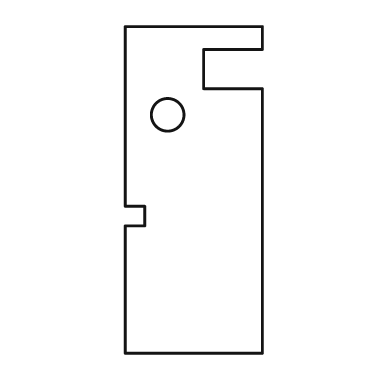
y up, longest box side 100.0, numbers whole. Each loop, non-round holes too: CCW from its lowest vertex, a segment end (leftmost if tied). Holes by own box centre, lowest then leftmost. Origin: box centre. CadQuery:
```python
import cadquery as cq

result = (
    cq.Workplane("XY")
    .moveTo(-21.0, -50.0)
    .lineTo(21.0, -50.0)
    .lineTo(21.0, 31.0)
    .lineTo(3.0, 31.0)
    .lineTo(3.0, 43.0)
    .lineTo(21.0, 43.0)
    .lineTo(21.0, 50.0)
    .lineTo(-21.0, 50.0)
    .lineTo(-21.0, -5.0)
    .lineTo(-15.0, -5.0)
    .lineTo(-15.0, -11.0)
    .lineTo(-21.0, -11.0)
    .close()
    .moveTo(-8.0, 23.0)
    .circle(5.0)
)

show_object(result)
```